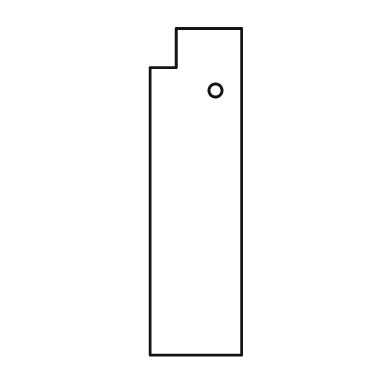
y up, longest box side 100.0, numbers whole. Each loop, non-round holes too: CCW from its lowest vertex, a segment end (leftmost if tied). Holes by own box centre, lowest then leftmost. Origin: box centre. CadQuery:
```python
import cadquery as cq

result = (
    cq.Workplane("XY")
    .moveTo(-14.0, -50.0)
    .lineTo(14.0, -50.0)
    .lineTo(14.0, 50.0)
    .lineTo(-6.0, 50.0)
    .lineTo(-6.0, 38.0)
    .lineTo(-14.0, 38.0)
    .close()
    .moveTo(6.0, 31.0)
    .circle(2.0)
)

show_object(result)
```